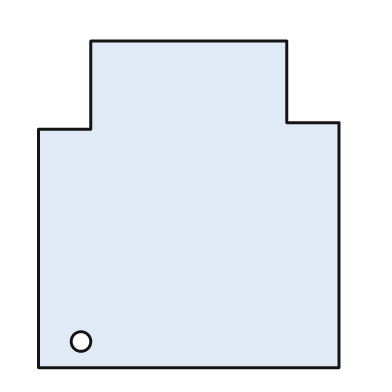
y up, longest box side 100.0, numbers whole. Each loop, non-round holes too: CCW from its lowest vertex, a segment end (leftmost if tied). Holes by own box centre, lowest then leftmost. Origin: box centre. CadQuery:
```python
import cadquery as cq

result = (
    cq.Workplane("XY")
    .moveTo(-46.0, -50.0)
    .lineTo(46.0, -50.0)
    .lineTo(46.0, 25.0)
    .lineTo(30.0, 25.0)
    .lineTo(30.0, 50.0)
    .lineTo(-30.0, 50.0)
    .lineTo(-30.0, 23.0)
    .lineTo(-46.0, 23.0)
    .close()
    .moveTo(-33.0, -42.0)
    .circle(3.0)
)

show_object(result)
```